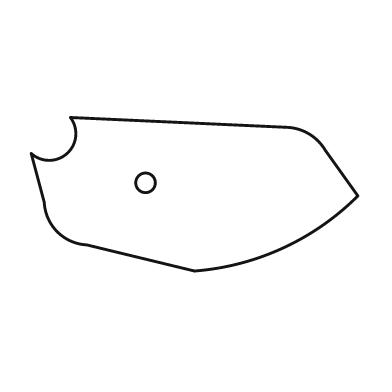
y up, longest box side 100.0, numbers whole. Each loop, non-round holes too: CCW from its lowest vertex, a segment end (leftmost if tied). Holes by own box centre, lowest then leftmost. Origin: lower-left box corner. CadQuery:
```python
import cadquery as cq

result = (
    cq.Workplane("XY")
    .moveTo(50.0, 0.0)
    .threePointArc((77.0, 7.0), (100.0, 23.0))
    .lineTo(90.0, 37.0)
    .threePointArc((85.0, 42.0), (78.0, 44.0))
    .lineTo(12.0, 47.0)
    .threePointArc((11.0, 36.0), (0.0, 36.0))
    .lineTo(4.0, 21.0)
    .threePointArc((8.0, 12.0), (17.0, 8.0))
    .close()
    .moveTo(35.0, 27.0)
    .circle(3.0)
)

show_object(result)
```